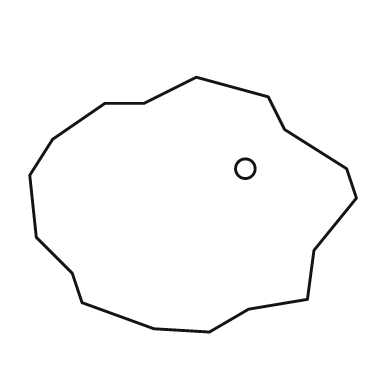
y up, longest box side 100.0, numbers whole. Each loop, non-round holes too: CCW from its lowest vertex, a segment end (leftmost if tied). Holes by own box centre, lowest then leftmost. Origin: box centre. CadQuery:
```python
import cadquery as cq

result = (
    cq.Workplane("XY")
    .moveTo(5.0, -39.0)
    .lineTo(17.0, -32.0)
    .lineTo(35.0, -29.0)
    .lineTo(37.0, -14.0)
    .lineTo(50.0, 2.0)
    .lineTo(47.0, 11.0)
    .lineTo(28.0, 23.0)
    .lineTo(23.0, 33.0)
    .lineTo(1.0, 39.0)
    .lineTo(-15.0, 31.0)
    .lineTo(-27.0, 31.0)
    .lineTo(-43.0, 20.0)
    .lineTo(-50.0, 9.0)
    .lineTo(-48.0, -10.0)
    .lineTo(-37.0, -21.0)
    .lineTo(-34.0, -30.0)
    .lineTo(-12.0, -38.0)
    .close()
    .moveTo(16.0, 11.0)
    .circle(3.0)
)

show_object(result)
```